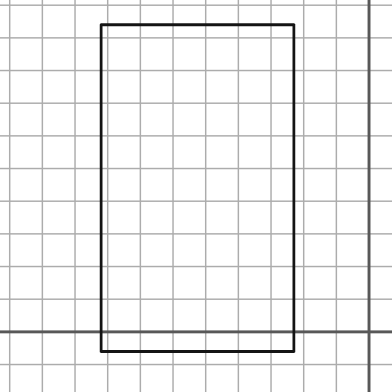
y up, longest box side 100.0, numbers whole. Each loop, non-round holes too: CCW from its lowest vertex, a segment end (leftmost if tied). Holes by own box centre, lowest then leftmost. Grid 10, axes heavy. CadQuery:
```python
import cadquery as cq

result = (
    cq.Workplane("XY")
    .moveTo(-82.0, -6.0)
    .lineTo(-23.0, -6.0)
    .lineTo(-23.0, 94.0)
    .lineTo(-82.0, 94.0)
    .close()
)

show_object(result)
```